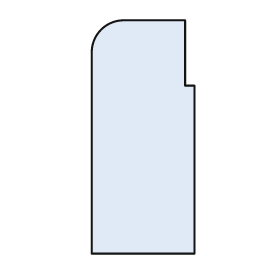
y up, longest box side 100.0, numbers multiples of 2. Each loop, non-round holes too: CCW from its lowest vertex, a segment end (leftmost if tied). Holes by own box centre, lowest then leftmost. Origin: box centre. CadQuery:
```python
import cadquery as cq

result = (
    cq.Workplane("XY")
    .moveTo(-22.0, -50.0)
    .lineTo(22.0, -50.0)
    .lineTo(22.0, 22.0)
    .lineTo(18.0, 22.0)
    .lineTo(18.0, 50.0)
    .lineTo(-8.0, 50.0)
    .threePointArc((-18.0, 46.0), (-22.0, 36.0))
    .close()
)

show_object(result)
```